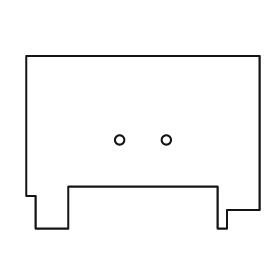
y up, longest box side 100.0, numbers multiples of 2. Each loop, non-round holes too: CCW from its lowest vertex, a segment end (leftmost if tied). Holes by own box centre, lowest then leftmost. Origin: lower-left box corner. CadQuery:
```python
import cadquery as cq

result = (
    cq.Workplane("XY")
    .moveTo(4.0, 0.0)
    .lineTo(18.0, 0.0)
    .lineTo(18.0, 18.0)
    .lineTo(82.0, 18.0)
    .lineTo(82.0, 0.0)
    .lineTo(86.0, 0.0)
    .lineTo(86.0, 8.0)
    .lineTo(100.0, 8.0)
    .lineTo(100.0, 74.0)
    .lineTo(0.0, 74.0)
    .lineTo(0.0, 14.0)
    .lineTo(4.0, 14.0)
    .close()
    .moveTo(40.0, 38.0)
    .circle(2.0)
    .moveTo(60.0, 38.0)
    .circle(2.0)
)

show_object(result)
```